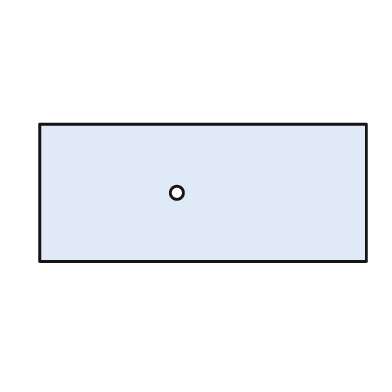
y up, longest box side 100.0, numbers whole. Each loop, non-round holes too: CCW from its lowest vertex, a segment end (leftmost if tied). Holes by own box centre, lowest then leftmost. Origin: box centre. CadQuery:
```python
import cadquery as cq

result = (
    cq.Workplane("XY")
    .moveTo(-50.0, -21.0)
    .lineTo(50.0, -21.0)
    .lineTo(50.0, 21.0)
    .lineTo(-50.0, 21.0)
    .close()
    .moveTo(-8.0, 0.0)
    .circle(2.0)
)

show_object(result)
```